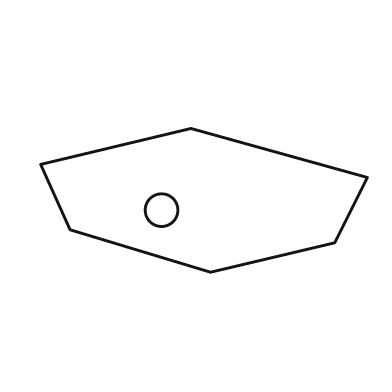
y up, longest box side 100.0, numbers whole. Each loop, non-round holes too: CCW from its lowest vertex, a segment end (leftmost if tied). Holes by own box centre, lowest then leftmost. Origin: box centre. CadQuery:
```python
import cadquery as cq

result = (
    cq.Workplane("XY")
    .moveTo(2.0, -22.0)
    .lineTo(40.0, -13.0)
    .lineTo(50.0, 7.0)
    .lineTo(-4.0, 22.0)
    .lineTo(-50.0, 11.0)
    .lineTo(-41.0, -9.0)
    .close()
    .moveTo(-13.0, -3.0)
    .circle(5.0)
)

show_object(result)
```